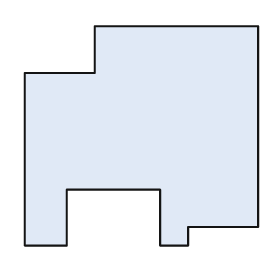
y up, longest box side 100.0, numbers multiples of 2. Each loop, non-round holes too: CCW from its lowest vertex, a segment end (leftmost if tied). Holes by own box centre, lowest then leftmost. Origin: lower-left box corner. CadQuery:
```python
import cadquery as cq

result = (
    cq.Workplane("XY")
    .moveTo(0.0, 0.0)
    .lineTo(18.0, 0.0)
    .lineTo(18.0, 24.0)
    .lineTo(58.0, 24.0)
    .lineTo(58.0, 0.0)
    .lineTo(70.0, 0.0)
    .lineTo(70.0, 8.0)
    .lineTo(100.0, 8.0)
    .lineTo(100.0, 94.0)
    .lineTo(30.0, 94.0)
    .lineTo(30.0, 74.0)
    .lineTo(0.0, 74.0)
    .close()
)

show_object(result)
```